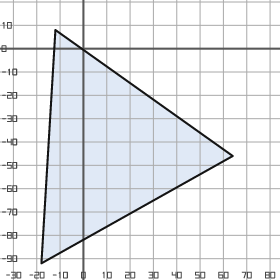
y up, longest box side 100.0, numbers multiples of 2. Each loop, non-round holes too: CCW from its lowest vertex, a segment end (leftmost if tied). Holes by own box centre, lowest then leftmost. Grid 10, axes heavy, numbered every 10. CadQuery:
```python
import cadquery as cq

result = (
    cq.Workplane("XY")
    .moveTo(-18.0, -92.0)
    .lineTo(64.0, -46.0)
    .lineTo(-12.0, 8.0)
    .close()
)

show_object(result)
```